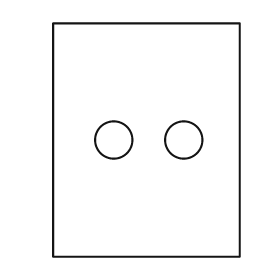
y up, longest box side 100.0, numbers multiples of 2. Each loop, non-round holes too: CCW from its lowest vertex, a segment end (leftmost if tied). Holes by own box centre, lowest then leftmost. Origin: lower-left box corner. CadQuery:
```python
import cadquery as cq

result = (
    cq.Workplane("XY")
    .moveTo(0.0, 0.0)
    .lineTo(80.0, 0.0)
    .lineTo(80.0, 100.0)
    .lineTo(0.0, 100.0)
    .close()
    .moveTo(26.0, 50.0)
    .circle(8.0)
    .moveTo(56.0, 50.0)
    .circle(8.0)
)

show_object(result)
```